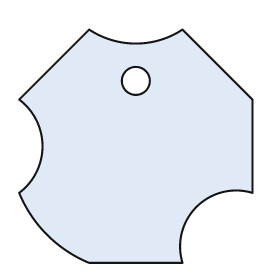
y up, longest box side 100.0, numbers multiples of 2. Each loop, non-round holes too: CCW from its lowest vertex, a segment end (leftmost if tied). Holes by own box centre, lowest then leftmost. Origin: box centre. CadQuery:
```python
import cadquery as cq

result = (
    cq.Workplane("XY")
    .moveTo(-20.0, -50.0)
    .lineTo(20.0, -50.0)
    .threePointArc((26.0, -26.0), (50.0, -20.0))
    .lineTo(50.0, 20.0)
    .lineTo(20.0, 50.0)
    .threePointArc((0.0, 44.0), (-20.0, 50.0))
    .lineTo(-50.0, 20.0)
    .threePointArc((-40.0, 0.0), (-50.0, -20.0))
    .threePointArc((-38.0, -38.0), (-20.0, -50.0))
    .close()
    .moveTo(0.0, 28.0)
    .circle(6.0)
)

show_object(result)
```